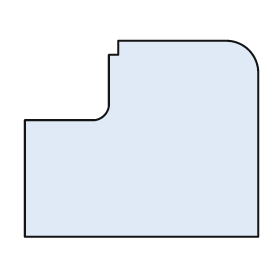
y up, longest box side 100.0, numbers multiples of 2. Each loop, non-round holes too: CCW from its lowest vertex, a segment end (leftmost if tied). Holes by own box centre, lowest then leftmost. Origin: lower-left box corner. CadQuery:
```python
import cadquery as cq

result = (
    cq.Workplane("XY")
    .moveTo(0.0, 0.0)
    .lineTo(100.0, 0.0)
    .lineTo(100.0, 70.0)
    .threePointArc((96.0, 80.0), (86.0, 84.0))
    .lineTo(40.0, 84.0)
    .lineTo(40.0, 78.0)
    .lineTo(36.0, 78.0)
    .lineTo(36.0, 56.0)
    .threePointArc((34.0, 52.0), (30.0, 50.0))
    .lineTo(0.0, 50.0)
    .close()
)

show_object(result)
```